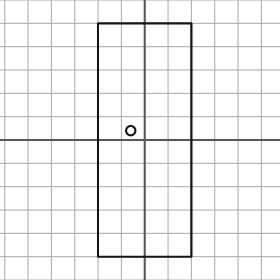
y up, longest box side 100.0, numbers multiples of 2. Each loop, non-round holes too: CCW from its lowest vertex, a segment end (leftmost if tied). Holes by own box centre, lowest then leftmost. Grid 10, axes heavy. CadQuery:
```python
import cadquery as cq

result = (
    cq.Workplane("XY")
    .moveTo(-20.0, -50.0)
    .lineTo(20.0, -50.0)
    .lineTo(20.0, 50.0)
    .lineTo(-20.0, 50.0)
    .close()
    .moveTo(-6.0, 4.0)
    .circle(2.0)
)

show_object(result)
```